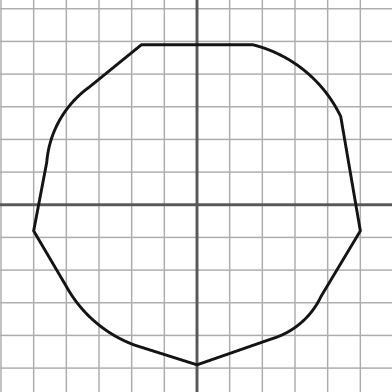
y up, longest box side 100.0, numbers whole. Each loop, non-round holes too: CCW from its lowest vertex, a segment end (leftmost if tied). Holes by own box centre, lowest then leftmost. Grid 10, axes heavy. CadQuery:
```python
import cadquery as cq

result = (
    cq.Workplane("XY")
    .moveTo(0.0, -49.0)
    .lineTo(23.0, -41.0)
    .threePointArc((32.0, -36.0), (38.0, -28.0))
    .lineTo(50.0, -8.0)
    .lineTo(44.0, 27.0)
    .threePointArc((33.0, 41.0), (17.0, 49.0))
    .lineTo(-17.0, 49.0)
    .lineTo(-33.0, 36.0)
    .threePointArc((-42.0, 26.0), (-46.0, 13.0))
    .lineTo(-50.0, -8.0)
    .lineTo(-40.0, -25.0)
    .threePointArc((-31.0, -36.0), (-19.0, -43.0))
    .close()
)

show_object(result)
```